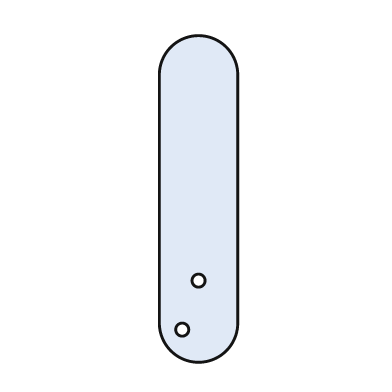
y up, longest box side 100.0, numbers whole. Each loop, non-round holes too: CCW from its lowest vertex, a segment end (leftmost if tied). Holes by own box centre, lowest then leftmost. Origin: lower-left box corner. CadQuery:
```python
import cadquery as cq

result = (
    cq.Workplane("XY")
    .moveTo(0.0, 12.0)
    .threePointArc((12.0, 0.0), (24.0, 12.0))
    .lineTo(24.0, 88.0)
    .threePointArc((12.0, 100.0), (0.0, 88.0))
    .close()
    .moveTo(7.0, 10.0)
    .circle(2.0)
    .moveTo(12.0, 25.0)
    .circle(2.0)
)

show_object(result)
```